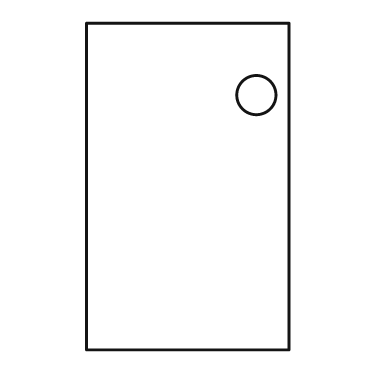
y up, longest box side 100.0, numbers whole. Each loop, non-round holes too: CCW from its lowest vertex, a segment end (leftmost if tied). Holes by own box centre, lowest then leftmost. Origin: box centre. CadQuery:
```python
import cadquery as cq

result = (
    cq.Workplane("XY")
    .moveTo(-31.0, -50.0)
    .lineTo(31.0, -50.0)
    .lineTo(31.0, 50.0)
    .lineTo(-31.0, 50.0)
    .close()
    .moveTo(21.0, 28.0)
    .circle(6.0)
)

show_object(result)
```